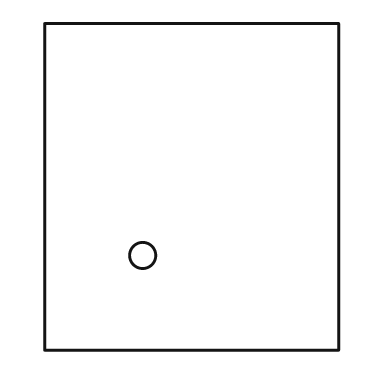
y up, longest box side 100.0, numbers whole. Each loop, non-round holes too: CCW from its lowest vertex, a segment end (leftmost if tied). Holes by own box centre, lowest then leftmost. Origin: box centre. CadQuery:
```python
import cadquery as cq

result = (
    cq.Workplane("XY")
    .moveTo(-45.0, -50.0)
    .lineTo(45.0, -50.0)
    .lineTo(45.0, 50.0)
    .lineTo(-45.0, 50.0)
    .close()
    .moveTo(-15.0, -21.0)
    .circle(4.0)
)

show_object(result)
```